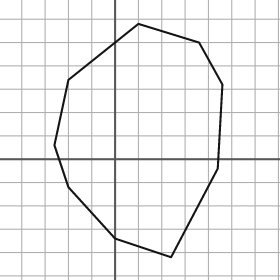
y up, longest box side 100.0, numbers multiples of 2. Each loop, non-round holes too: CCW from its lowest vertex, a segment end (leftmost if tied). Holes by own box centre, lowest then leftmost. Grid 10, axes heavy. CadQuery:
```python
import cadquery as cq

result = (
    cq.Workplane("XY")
    .moveTo(24.0, -42.0)
    .lineTo(44.0, -4.0)
    .lineTo(46.0, 32.0)
    .lineTo(36.0, 50.0)
    .lineTo(10.0, 58.0)
    .lineTo(-20.0, 34.0)
    .lineTo(-26.0, 6.0)
    .lineTo(-20.0, -12.0)
    .lineTo(0.0, -34.0)
    .close()
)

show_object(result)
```